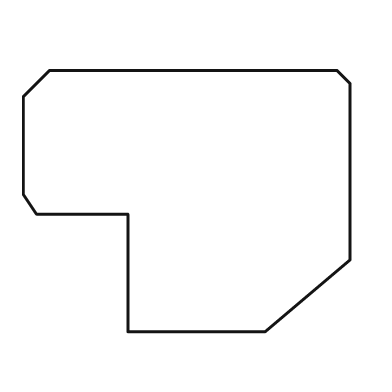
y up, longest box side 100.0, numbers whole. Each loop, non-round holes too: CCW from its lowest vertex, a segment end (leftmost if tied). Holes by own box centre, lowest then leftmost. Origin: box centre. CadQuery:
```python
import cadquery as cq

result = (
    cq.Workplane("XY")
    .moveTo(-18.0, -40.0)
    .lineTo(24.0, -40.0)
    .lineTo(50.0, -18.0)
    .lineTo(50.0, 36.0)
    .lineTo(46.0, 40.0)
    .lineTo(-42.0, 40.0)
    .lineTo(-50.0, 32.0)
    .lineTo(-50.0, 2.0)
    .lineTo(-46.0, -4.0)
    .lineTo(-18.0, -4.0)
    .close()
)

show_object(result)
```